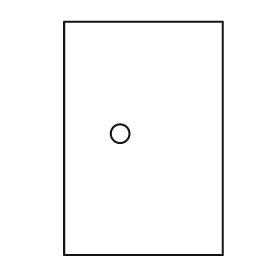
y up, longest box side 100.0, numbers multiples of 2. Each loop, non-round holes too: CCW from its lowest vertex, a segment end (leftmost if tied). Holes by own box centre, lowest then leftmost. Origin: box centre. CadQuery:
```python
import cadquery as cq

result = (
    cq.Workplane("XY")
    .moveTo(-34.0, -50.0)
    .lineTo(34.0, -50.0)
    .lineTo(34.0, 50.0)
    .lineTo(-34.0, 50.0)
    .close()
    .moveTo(-10.0, 2.0)
    .circle(4.0)
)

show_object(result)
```